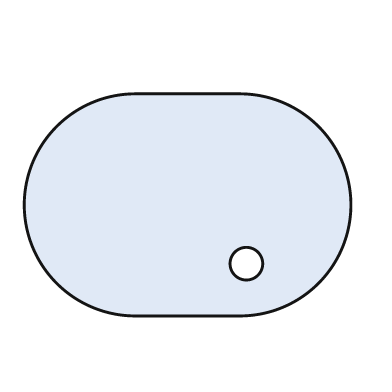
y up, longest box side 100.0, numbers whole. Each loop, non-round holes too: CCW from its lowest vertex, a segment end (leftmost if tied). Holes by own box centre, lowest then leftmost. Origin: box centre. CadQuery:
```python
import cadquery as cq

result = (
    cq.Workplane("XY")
    .moveTo(-16.0, -34.0)
    .lineTo(16.0, -34.0)
    .threePointArc((50.0, 0.0), (16.0, 34.0))
    .lineTo(-16.0, 34.0)
    .threePointArc((-50.0, 0.0), (-16.0, -34.0))
    .close()
    .moveTo(18.0, -18.0)
    .circle(5.0)
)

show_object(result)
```